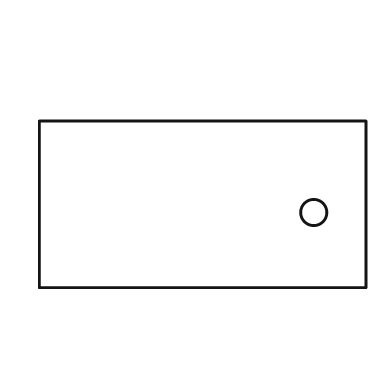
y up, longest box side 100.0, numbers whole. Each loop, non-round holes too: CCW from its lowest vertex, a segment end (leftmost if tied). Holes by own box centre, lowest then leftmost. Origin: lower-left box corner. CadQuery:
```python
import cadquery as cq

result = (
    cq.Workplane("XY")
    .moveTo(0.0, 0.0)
    .lineTo(100.0, 0.0)
    .lineTo(100.0, 51.0)
    .lineTo(0.0, 51.0)
    .close()
    .moveTo(84.0, 23.0)
    .circle(4.0)
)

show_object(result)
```